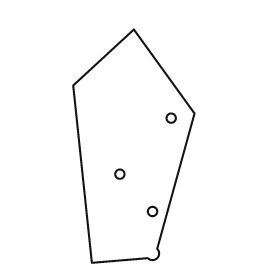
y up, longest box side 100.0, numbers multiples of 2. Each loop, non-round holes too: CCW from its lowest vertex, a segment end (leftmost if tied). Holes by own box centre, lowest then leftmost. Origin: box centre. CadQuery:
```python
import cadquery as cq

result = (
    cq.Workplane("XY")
    .moveTo(-18.0, -50.0)
    .lineTo(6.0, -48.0)
    .threePointArc((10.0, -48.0), (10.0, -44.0))
    .lineTo(26.0, 14.0)
    .lineTo(0.0, 50.0)
    .lineTo(-26.0, 26.0)
    .close()
    .moveTo(8.0, -28.0)
    .circle(2.0)
    .moveTo(-6.0, -12.0)
    .circle(2.0)
    .moveTo(16.0, 12.0)
    .circle(2.0)
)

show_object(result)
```